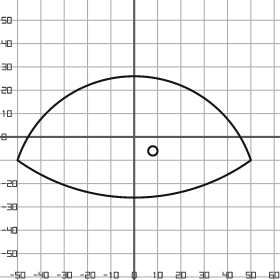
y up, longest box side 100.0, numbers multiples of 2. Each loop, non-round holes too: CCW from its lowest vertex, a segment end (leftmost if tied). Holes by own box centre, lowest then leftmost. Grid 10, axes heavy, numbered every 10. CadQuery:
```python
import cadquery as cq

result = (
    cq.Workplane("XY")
    .moveTo(-50.0, -10.0)
    .threePointArc((0.0, -26.0), (50.0, -10.0))
    .threePointArc((0.0, 26.0), (-50.0, -10.0))
    .close()
    .moveTo(8.0, -6.0)
    .circle(2.0)
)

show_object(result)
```